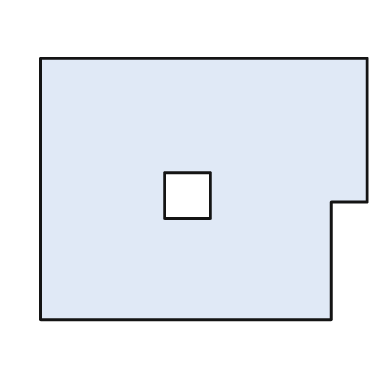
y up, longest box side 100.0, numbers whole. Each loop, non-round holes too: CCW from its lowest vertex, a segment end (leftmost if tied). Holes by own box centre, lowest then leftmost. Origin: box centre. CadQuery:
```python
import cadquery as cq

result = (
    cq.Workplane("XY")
    .moveTo(-50.0, -40.0)
    .lineTo(39.0, -40.0)
    .lineTo(39.0, -4.0)
    .lineTo(50.0, -4.0)
    .lineTo(50.0, 40.0)
    .lineTo(-50.0, 40.0)
    .close()
    .moveTo(-12.0, -9.0)
    .lineTo(2.0, -9.0)
    .lineTo(2.0, 5.0)
    .lineTo(-12.0, 5.0)
    .close()
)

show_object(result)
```